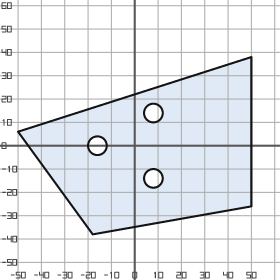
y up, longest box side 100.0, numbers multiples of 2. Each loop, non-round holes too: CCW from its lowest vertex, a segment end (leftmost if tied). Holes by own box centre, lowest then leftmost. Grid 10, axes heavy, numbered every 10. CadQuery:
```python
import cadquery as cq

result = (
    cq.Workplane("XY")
    .moveTo(-18.0, -38.0)
    .lineTo(50.0, -26.0)
    .lineTo(50.0, 38.0)
    .lineTo(-50.0, 6.0)
    .close()
    .moveTo(8.0, -14.0)
    .circle(4.0)
    .moveTo(-16.0, 0.0)
    .circle(4.0)
    .moveTo(8.0, 14.0)
    .circle(4.0)
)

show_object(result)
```